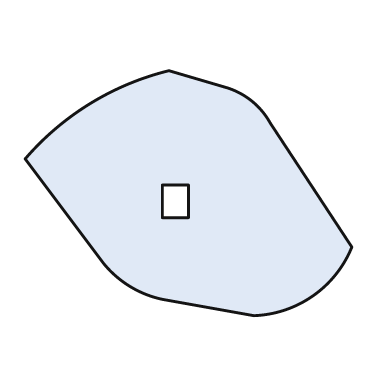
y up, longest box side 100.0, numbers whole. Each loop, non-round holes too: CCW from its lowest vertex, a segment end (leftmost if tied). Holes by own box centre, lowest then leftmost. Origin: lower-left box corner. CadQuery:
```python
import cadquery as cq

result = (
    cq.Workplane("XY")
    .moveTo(70.0, 0.0)
    .threePointArc((88.0, 6.0), (100.0, 21.0))
    .lineTo(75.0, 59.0)
    .threePointArc((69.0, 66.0), (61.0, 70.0))
    .lineTo(44.0, 75.0)
    .threePointArc((20.0, 65.0), (0.0, 48.0))
    .lineTo(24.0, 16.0)
    .threePointArc((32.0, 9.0), (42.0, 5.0))
    .close()
    .moveTo(42.0, 30.0)
    .lineTo(50.0, 30.0)
    .lineTo(50.0, 40.0)
    .lineTo(42.0, 40.0)
    .close()
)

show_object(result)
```